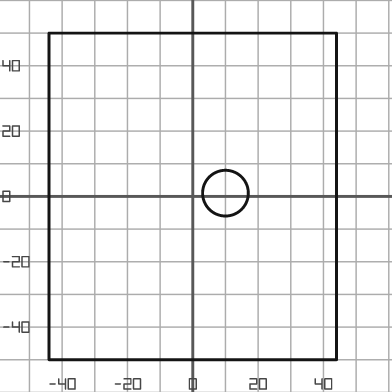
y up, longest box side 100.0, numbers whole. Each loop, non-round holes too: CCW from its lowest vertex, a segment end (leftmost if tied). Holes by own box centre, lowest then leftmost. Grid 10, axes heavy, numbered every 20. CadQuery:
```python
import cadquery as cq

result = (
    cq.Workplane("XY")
    .moveTo(-44.0, -50.0)
    .lineTo(44.0, -50.0)
    .lineTo(44.0, 50.0)
    .lineTo(-44.0, 50.0)
    .close()
    .moveTo(10.0, 1.0)
    .circle(7.0)
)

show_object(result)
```